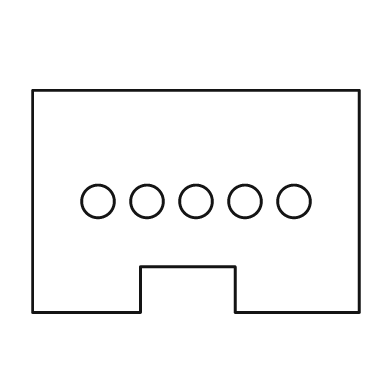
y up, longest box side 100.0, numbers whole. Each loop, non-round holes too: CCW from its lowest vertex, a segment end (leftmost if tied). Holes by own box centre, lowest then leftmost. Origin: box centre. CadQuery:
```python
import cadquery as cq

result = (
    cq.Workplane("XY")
    .moveTo(-50.0, -34.0)
    .lineTo(-17.0, -34.0)
    .lineTo(-17.0, -20.0)
    .lineTo(12.0, -20.0)
    .lineTo(12.0, -34.0)
    .lineTo(50.0, -34.0)
    .lineTo(50.0, 34.0)
    .lineTo(-50.0, 34.0)
    .close()
    .moveTo(-30.0, 0.0)
    .circle(5.0)
    .moveTo(-15.0, 0.0)
    .circle(5.0)
    .moveTo(0.0, 0.0)
    .circle(5.0)
    .moveTo(15.0, 0.0)
    .circle(5.0)
    .moveTo(30.0, 0.0)
    .circle(5.0)
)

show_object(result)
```